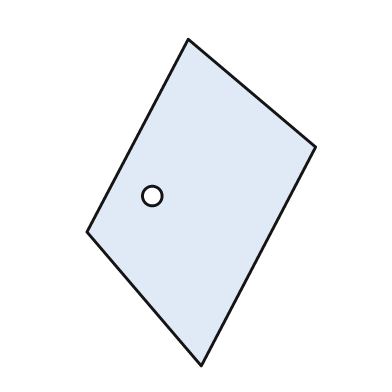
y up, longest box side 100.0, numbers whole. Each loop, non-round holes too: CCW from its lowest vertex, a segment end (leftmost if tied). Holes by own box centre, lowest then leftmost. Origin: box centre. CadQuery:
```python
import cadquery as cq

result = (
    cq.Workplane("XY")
    .moveTo(0.0, -50.0)
    .lineTo(35.0, 17.0)
    .lineTo(-4.0, 50.0)
    .lineTo(-35.0, -9.0)
    .close()
    .moveTo(-15.0, 2.0)
    .circle(3.0)
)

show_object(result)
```